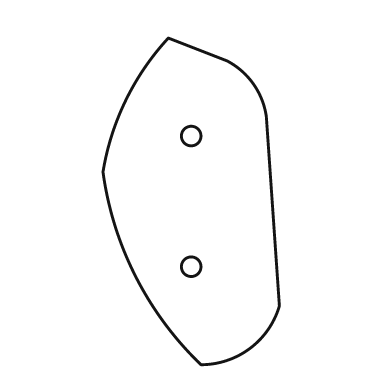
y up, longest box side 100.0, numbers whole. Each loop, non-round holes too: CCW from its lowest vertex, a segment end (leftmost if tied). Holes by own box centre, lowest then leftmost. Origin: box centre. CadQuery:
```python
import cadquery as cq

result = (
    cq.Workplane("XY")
    .moveTo(3.0, -50.0)
    .threePointArc((18.0, -45.0), (27.0, -32.0))
    .lineTo(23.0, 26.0)
    .threePointArc((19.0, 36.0), (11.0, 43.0))
    .lineTo(-7.0, 50.0)
    .threePointArc((-20.0, 31.0), (-27.0, 9.0))
    .threePointArc((-17.0, -23.0), (3.0, -50.0))
    .close()
    .moveTo(0.0, -20.0)
    .circle(3.0)
    .moveTo(0.0, 20.0)
    .circle(3.0)
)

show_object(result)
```